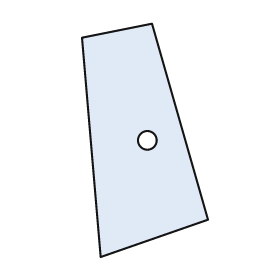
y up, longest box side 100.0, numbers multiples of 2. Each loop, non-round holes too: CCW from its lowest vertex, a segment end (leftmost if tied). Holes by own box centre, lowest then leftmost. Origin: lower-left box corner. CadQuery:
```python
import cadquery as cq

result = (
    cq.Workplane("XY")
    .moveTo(8.0, 0.0)
    .lineTo(54.0, 16.0)
    .lineTo(30.0, 100.0)
    .lineTo(0.0, 94.0)
    .close()
    .moveTo(28.0, 50.0)
    .circle(4.0)
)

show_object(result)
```